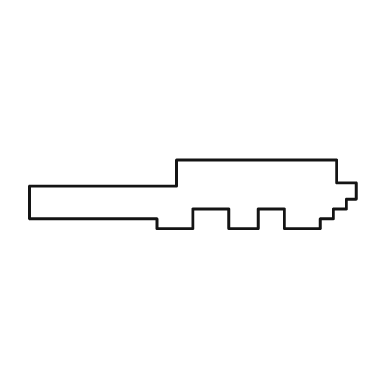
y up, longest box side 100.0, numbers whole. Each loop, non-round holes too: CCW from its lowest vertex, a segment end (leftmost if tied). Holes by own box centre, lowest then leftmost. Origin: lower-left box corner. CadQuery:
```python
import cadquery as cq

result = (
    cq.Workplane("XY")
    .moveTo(39.0, 0.0)
    .lineTo(50.0, 0.0)
    .lineTo(50.0, 6.0)
    .lineTo(61.0, 6.0)
    .lineTo(61.0, 0.0)
    .lineTo(70.0, 0.0)
    .lineTo(70.0, 6.0)
    .lineTo(78.0, 6.0)
    .lineTo(78.0, 0.0)
    .lineTo(89.0, 0.0)
    .lineTo(89.0, 3.0)
    .lineTo(93.0, 3.0)
    .lineTo(93.0, 6.0)
    .lineTo(97.0, 6.0)
    .lineTo(97.0, 9.0)
    .lineTo(100.0, 9.0)
    .lineTo(100.0, 14.0)
    .lineTo(94.0, 14.0)
    .lineTo(94.0, 21.0)
    .lineTo(45.0, 21.0)
    .lineTo(45.0, 13.0)
    .lineTo(0.0, 13.0)
    .lineTo(0.0, 3.0)
    .lineTo(39.0, 3.0)
    .close()
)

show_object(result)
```